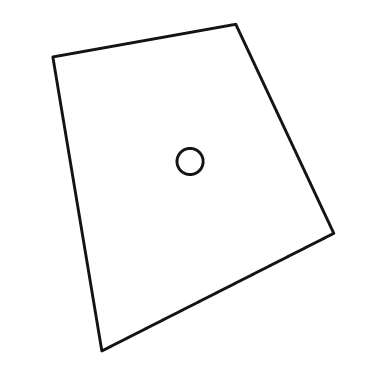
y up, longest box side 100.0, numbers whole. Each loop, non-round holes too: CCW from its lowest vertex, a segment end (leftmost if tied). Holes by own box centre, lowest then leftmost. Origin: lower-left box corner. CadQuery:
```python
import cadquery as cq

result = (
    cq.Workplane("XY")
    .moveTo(15.0, 0.0)
    .lineTo(86.0, 36.0)
    .lineTo(56.0, 100.0)
    .lineTo(0.0, 90.0)
    .close()
    .moveTo(42.0, 58.0)
    .circle(4.0)
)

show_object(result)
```